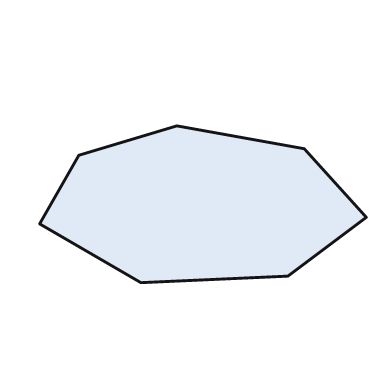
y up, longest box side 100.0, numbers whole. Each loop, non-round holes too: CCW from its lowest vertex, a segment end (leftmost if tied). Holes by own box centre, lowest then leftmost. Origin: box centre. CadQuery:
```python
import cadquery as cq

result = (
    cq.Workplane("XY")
    .moveTo(-19.0, -24.0)
    .lineTo(26.0, -22.0)
    .lineTo(50.0, -4.0)
    .lineTo(31.0, 17.0)
    .lineTo(-8.0, 24.0)
    .lineTo(-38.0, 15.0)
    .lineTo(-50.0, -6.0)
    .close()
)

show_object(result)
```